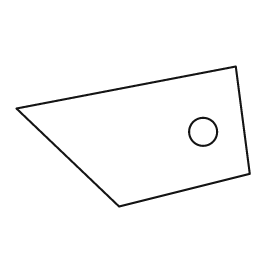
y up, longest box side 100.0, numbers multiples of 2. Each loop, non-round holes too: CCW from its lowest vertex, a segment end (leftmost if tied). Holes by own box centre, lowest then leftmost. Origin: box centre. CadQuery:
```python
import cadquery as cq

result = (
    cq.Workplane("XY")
    .moveTo(-6.0, -30.0)
    .lineTo(50.0, -16.0)
    .lineTo(44.0, 30.0)
    .lineTo(-50.0, 12.0)
    .close()
    .moveTo(30.0, 2.0)
    .circle(6.0)
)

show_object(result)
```